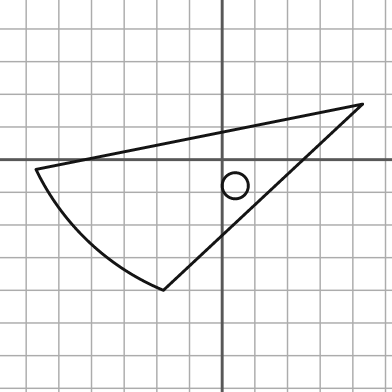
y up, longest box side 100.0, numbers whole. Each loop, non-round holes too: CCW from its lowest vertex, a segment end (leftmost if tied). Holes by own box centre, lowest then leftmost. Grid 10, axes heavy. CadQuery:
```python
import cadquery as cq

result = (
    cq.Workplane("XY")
    .moveTo(-18.0, -40.0)
    .lineTo(43.0, 17.0)
    .lineTo(-57.0, -3.0)
    .threePointArc((-41.0, -25.0), (-18.0, -40.0))
    .close()
    .moveTo(4.0, -8.0)
    .circle(4.0)
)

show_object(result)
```